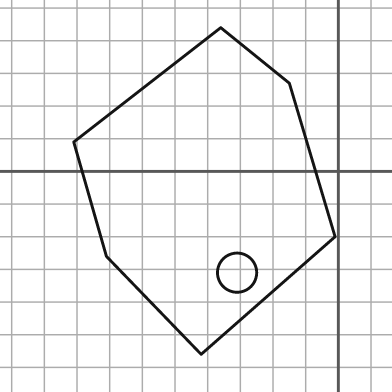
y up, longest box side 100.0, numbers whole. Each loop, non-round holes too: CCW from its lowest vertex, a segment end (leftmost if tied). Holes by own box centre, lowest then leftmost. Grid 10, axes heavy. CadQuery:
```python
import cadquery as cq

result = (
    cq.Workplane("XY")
    .moveTo(-42.0, -56.0)
    .lineTo(-1.0, -20.0)
    .lineTo(-15.0, 27.0)
    .lineTo(-36.0, 44.0)
    .lineTo(-81.0, 9.0)
    .lineTo(-71.0, -26.0)
    .close()
    .moveTo(-31.0, -31.0)
    .circle(6.0)
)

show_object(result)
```